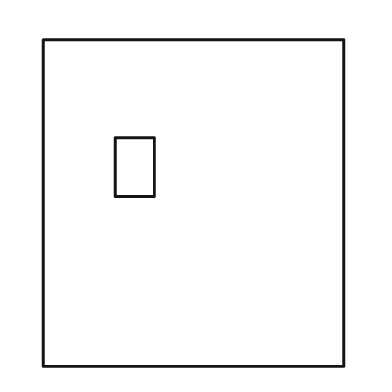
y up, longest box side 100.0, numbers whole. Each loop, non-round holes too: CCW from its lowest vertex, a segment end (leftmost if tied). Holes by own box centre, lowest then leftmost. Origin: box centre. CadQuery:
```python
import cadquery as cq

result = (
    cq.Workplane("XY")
    .moveTo(-46.0, -50.0)
    .lineTo(46.0, -50.0)
    .lineTo(46.0, 50.0)
    .lineTo(-46.0, 50.0)
    .close()
    .moveTo(-24.0, 2.0)
    .lineTo(-12.0, 2.0)
    .lineTo(-12.0, 20.0)
    .lineTo(-24.0, 20.0)
    .close()
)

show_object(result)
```